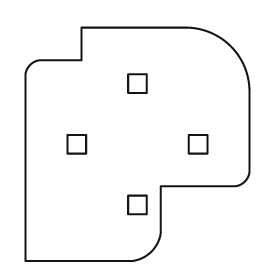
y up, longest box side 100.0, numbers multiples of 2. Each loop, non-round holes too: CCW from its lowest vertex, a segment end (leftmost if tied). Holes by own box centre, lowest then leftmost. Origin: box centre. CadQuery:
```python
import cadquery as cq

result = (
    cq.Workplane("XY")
    .moveTo(-48.0, -50.0)
    .lineTo(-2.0, -50.0)
    .threePointArc((6.0, -46.0), (10.0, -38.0))
    .lineTo(10.0, -18.0)
    .lineTo(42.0, -18.0)
    .threePointArc((46.0, -16.0), (48.0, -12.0))
    .lineTo(48.0, 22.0)
    .threePointArc((40.0, 42.0), (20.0, 50.0))
    .lineTo(-24.0, 50.0)
    .lineTo(-24.0, 36.0)
    .lineTo(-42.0, 36.0)
    .threePointArc((-46.0, 34.0), (-48.0, 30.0))
    .close()
    .moveTo(-4.0, -30.0)
    .lineTo(4.0, -30.0)
    .lineTo(4.0, -22.0)
    .lineTo(-4.0, -22.0)
    .close()
    .moveTo(-30.0, -4.0)
    .lineTo(-22.0, -4.0)
    .lineTo(-22.0, 4.0)
    .lineTo(-30.0, 4.0)
    .close()
    .moveTo(22.0, -4.0)
    .lineTo(30.0, -4.0)
    .lineTo(30.0, 4.0)
    .lineTo(22.0, 4.0)
    .close()
    .moveTo(-4.0, 22.0)
    .lineTo(4.0, 22.0)
    .lineTo(4.0, 30.0)
    .lineTo(-4.0, 30.0)
    .close()
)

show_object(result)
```